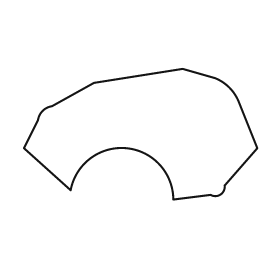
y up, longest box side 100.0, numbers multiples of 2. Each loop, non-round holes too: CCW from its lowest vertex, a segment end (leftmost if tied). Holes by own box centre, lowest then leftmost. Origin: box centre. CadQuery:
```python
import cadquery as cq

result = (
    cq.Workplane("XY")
    .moveTo(14.0, -28.0)
    .lineTo(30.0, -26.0)
    .threePointArc((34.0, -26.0), (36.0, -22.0))
    .lineTo(50.0, -6.0)
    .lineTo(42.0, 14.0)
    .threePointArc((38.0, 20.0), (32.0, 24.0))
    .lineTo(18.0, 28.0)
    .lineTo(-20.0, 22.0)
    .lineTo(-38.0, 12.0)
    .threePointArc((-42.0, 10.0), (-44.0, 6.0))
    .lineTo(-50.0, -6.0)
    .lineTo(-30.0, -24.0)
    .threePointArc((-6.0, -6.0), (14.0, -28.0))
    .close()
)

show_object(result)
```